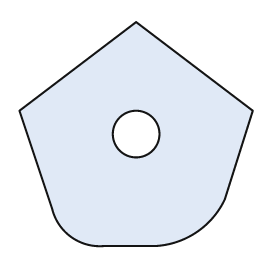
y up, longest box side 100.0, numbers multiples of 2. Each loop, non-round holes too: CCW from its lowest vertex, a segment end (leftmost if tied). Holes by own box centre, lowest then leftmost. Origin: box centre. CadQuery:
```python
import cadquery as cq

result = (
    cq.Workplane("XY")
    .moveTo(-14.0, -48.0)
    .lineTo(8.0, -48.0)
    .threePointArc((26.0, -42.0), (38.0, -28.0))
    .lineTo(50.0, 10.0)
    .lineTo(0.0, 48.0)
    .lineTo(-50.0, 10.0)
    .lineTo(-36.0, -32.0)
    .threePointArc((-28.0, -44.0), (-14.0, -48.0))
    .close()
    .moveTo(0.0, 0.0)
    .circle(10.0)
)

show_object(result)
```